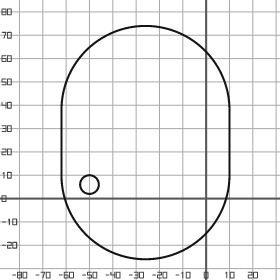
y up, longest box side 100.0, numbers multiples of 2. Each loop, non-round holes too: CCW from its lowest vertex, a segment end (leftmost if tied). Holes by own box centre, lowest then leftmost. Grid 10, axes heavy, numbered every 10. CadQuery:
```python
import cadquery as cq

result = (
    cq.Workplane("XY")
    .moveTo(-62.0, 10.0)
    .threePointArc((-26.0, -26.0), (10.0, 10.0))
    .lineTo(10.0, 38.0)
    .threePointArc((-26.0, 74.0), (-62.0, 38.0))
    .close()
    .moveTo(-50.0, 6.0)
    .circle(4.0)
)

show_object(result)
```